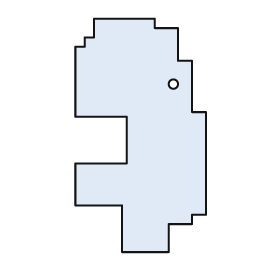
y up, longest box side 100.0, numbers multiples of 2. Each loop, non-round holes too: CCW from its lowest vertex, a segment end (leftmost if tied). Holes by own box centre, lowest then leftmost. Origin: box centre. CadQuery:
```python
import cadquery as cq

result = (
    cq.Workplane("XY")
    .moveTo(-8.0, -50.0)
    .lineTo(12.0, -50.0)
    .lineTo(12.0, -38.0)
    .lineTo(22.0, -38.0)
    .lineTo(22.0, -34.0)
    .lineTo(28.0, -34.0)
    .lineTo(28.0, 10.0)
    .lineTo(22.0, 10.0)
    .lineTo(22.0, 32.0)
    .lineTo(16.0, 32.0)
    .lineTo(16.0, 46.0)
    .lineTo(6.0, 46.0)
    .lineTo(6.0, 50.0)
    .lineTo(-20.0, 50.0)
    .lineTo(-20.0, 42.0)
    .lineTo(-24.0, 42.0)
    .lineTo(-24.0, 38.0)
    .lineTo(-28.0, 38.0)
    .lineTo(-28.0, 8.0)
    .lineTo(-6.0, 8.0)
    .lineTo(-6.0, -12.0)
    .lineTo(-28.0, -12.0)
    .lineTo(-28.0, -30.0)
    .lineTo(-8.0, -30.0)
    .close()
    .moveTo(14.0, 22.0)
    .circle(2.0)
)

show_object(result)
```